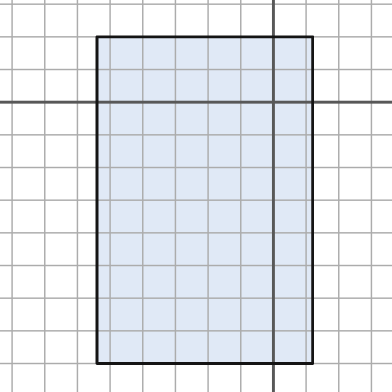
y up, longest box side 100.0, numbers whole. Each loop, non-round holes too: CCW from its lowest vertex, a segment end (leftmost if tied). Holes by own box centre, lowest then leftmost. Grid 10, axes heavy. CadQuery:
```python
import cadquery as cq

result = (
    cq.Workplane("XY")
    .moveTo(-54.0, -80.0)
    .lineTo(12.0, -80.0)
    .lineTo(12.0, 20.0)
    .lineTo(-54.0, 20.0)
    .close()
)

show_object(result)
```